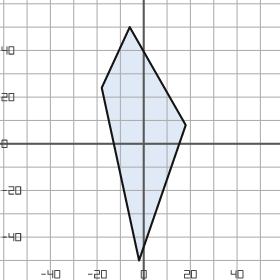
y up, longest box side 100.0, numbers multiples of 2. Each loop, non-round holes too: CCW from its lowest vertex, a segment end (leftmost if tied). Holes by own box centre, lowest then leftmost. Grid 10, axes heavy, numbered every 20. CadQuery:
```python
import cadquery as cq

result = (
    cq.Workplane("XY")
    .moveTo(-2.0, -50.0)
    .lineTo(18.0, 8.0)
    .lineTo(-6.0, 50.0)
    .lineTo(-18.0, 24.0)
    .close()
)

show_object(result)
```